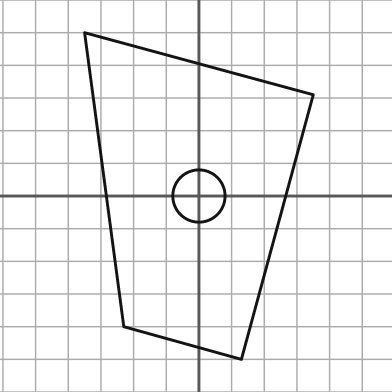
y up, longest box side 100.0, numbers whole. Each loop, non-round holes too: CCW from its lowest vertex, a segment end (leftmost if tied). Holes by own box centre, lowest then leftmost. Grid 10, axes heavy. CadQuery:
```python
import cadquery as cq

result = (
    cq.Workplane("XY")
    .moveTo(13.0, -50.0)
    .lineTo(35.0, 31.0)
    .lineTo(-35.0, 50.0)
    .lineTo(-23.0, -40.0)
    .close()
    .moveTo(0.0, 0.0)
    .circle(8.0)
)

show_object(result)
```